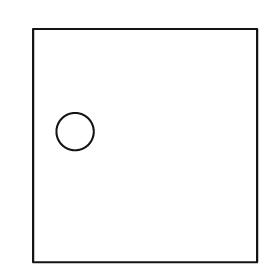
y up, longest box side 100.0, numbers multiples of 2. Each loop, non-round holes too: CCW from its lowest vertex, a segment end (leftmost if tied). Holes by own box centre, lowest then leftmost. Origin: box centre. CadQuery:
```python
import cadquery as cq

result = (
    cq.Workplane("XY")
    .moveTo(-48.0, -50.0)
    .lineTo(48.0, -50.0)
    .lineTo(48.0, 50.0)
    .lineTo(-48.0, 50.0)
    .close()
    .moveTo(-30.0, 6.0)
    .circle(8.0)
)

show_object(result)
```